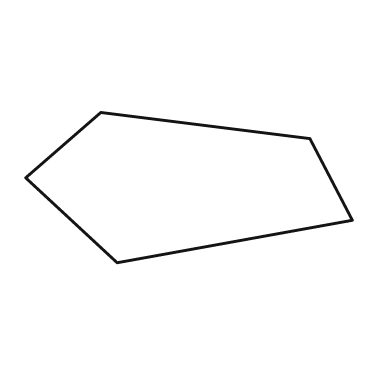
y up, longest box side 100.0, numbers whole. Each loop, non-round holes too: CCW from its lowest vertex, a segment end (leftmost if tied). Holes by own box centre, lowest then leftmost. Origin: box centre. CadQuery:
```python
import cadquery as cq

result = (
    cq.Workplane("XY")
    .moveTo(-22.0, -23.0)
    .lineTo(50.0, -10.0)
    .lineTo(37.0, 15.0)
    .lineTo(-27.0, 23.0)
    .lineTo(-50.0, 3.0)
    .close()
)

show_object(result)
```